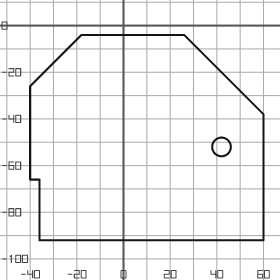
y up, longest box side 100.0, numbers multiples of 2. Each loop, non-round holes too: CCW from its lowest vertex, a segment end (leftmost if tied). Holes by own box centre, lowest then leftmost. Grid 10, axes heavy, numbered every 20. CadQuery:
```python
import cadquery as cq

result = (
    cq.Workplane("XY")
    .moveTo(-36.0, -92.0)
    .lineTo(60.0, -92.0)
    .lineTo(60.0, -38.0)
    .lineTo(26.0, -4.0)
    .lineTo(-18.0, -4.0)
    .lineTo(-40.0, -26.0)
    .lineTo(-40.0, -66.0)
    .lineTo(-36.0, -66.0)
    .close()
    .moveTo(42.0, -52.0)
    .circle(4.0)
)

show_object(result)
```